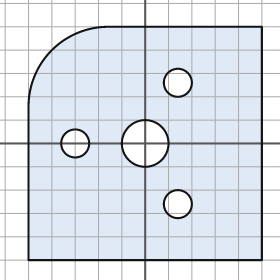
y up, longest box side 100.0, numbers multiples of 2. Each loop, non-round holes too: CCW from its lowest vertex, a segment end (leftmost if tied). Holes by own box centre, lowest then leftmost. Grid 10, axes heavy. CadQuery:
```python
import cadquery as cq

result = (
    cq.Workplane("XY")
    .moveTo(-50.0, -50.0)
    .lineTo(50.0, -50.0)
    .lineTo(50.0, 50.0)
    .lineTo(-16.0, 50.0)
    .threePointArc((-40.0, 40.0), (-50.0, 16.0))
    .close()
    .moveTo(14.0, -26.0)
    .circle(6.0)
    .moveTo(-30.0, 0.0)
    .circle(6.0)
    .moveTo(0.0, 0.0)
    .circle(10.0)
    .moveTo(14.0, 26.0)
    .circle(6.0)
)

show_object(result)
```